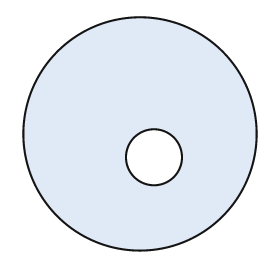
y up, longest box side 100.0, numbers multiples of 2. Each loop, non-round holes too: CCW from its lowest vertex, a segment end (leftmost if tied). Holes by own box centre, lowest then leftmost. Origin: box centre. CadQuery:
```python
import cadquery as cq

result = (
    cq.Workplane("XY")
    .moveTo(0.0, 0.0)
    .circle(50.0)
    .moveTo(6.0, -10.0)
    .circle(12.0)
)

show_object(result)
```